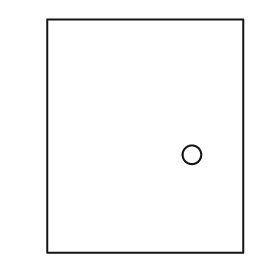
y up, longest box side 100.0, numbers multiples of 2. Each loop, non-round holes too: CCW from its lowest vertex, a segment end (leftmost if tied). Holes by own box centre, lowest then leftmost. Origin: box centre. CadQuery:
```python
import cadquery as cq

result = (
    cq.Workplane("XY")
    .moveTo(-42.0, -50.0)
    .lineTo(42.0, -50.0)
    .lineTo(42.0, 50.0)
    .lineTo(-42.0, 50.0)
    .close()
    .moveTo(20.0, -8.0)
    .circle(4.0)
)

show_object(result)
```